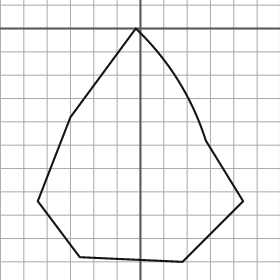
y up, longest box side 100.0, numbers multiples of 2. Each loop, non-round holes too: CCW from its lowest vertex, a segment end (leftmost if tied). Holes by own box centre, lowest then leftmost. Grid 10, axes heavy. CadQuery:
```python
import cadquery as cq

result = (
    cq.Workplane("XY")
    .moveTo(18.0, -100.0)
    .lineTo(44.0, -74.0)
    .lineTo(28.0, -48.0)
    .threePointArc((16.0, -22.0), (-2.0, 0.0))
    .lineTo(-30.0, -38.0)
    .lineTo(-44.0, -74.0)
    .lineTo(-26.0, -98.0)
    .close()
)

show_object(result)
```